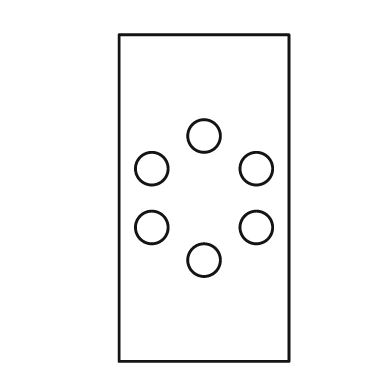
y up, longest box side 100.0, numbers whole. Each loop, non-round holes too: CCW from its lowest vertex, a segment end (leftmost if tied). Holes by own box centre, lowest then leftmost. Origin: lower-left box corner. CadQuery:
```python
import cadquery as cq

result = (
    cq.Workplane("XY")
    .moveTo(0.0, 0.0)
    .lineTo(52.0, 0.0)
    .lineTo(52.0, 100.0)
    .lineTo(0.0, 100.0)
    .close()
    .moveTo(26.0, 31.0)
    .circle(5.0)
    .moveTo(10.0, 41.0)
    .circle(5.0)
    .moveTo(42.0, 41.0)
    .circle(5.0)
    .moveTo(10.0, 59.0)
    .circle(5.0)
    .moveTo(42.0, 59.0)
    .circle(5.0)
    .moveTo(26.0, 69.0)
    .circle(5.0)
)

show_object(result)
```